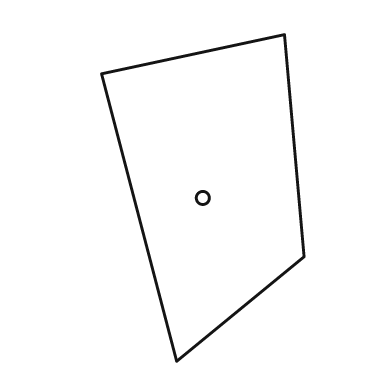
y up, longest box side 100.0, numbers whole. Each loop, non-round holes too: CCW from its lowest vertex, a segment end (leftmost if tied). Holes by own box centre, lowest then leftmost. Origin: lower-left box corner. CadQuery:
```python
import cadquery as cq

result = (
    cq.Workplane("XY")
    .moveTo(23.0, 0.0)
    .lineTo(62.0, 32.0)
    .lineTo(56.0, 100.0)
    .lineTo(0.0, 88.0)
    .close()
    .moveTo(31.0, 50.0)
    .circle(2.0)
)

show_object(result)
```